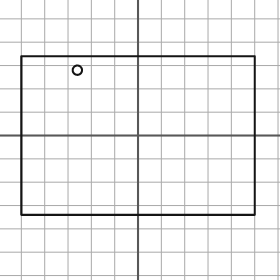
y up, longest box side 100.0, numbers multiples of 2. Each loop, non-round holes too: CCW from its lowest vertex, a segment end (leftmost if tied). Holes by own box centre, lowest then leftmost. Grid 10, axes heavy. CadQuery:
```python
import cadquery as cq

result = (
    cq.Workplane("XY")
    .moveTo(-50.0, -34.0)
    .lineTo(50.0, -34.0)
    .lineTo(50.0, 34.0)
    .lineTo(-50.0, 34.0)
    .close()
    .moveTo(-26.0, 28.0)
    .circle(2.0)
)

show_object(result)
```